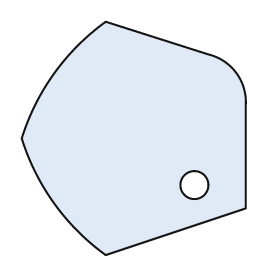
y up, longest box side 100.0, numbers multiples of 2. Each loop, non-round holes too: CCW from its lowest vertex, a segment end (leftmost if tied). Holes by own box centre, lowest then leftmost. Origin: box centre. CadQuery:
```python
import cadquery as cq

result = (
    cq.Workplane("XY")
    .moveTo(-12.0, -50.0)
    .lineTo(48.0, -30.0)
    .lineTo(48.0, 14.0)
    .threePointArc((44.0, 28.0), (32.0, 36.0))
    .lineTo(-12.0, 50.0)
    .threePointArc((-34.0, 28.0), (-48.0, 0.0))
    .threePointArc((-34.0, -28.0), (-12.0, -50.0))
    .close()
    .moveTo(26.0, -20.0)
    .circle(6.0)
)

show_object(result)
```